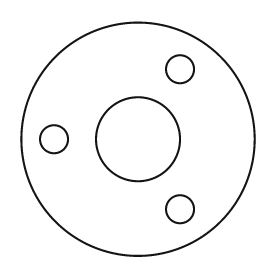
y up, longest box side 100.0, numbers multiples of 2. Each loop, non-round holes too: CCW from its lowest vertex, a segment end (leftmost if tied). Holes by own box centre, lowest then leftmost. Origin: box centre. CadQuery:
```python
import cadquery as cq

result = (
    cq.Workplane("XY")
    .moveTo(0.0, 0.0)
    .circle(50.0)
    .moveTo(18.0, -30.0)
    .circle(6.0)
    .moveTo(-36.0, 0.0)
    .circle(6.0)
    .moveTo(0.0, 0.0)
    .circle(18.0)
    .moveTo(18.0, 30.0)
    .circle(6.0)
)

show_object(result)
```